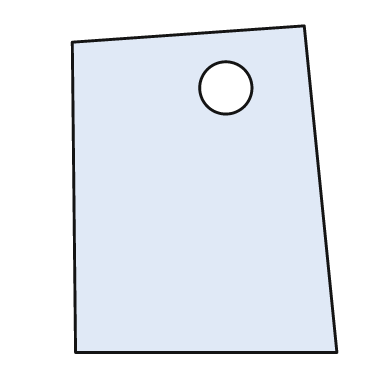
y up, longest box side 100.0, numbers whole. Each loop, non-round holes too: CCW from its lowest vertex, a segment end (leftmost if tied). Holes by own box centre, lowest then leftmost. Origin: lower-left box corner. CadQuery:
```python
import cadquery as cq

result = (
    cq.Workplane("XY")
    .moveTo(1.0, 0.0)
    .lineTo(81.0, 0.0)
    .lineTo(71.0, 100.0)
    .lineTo(0.0, 95.0)
    .close()
    .moveTo(47.0, 81.0)
    .circle(8.0)
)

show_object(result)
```